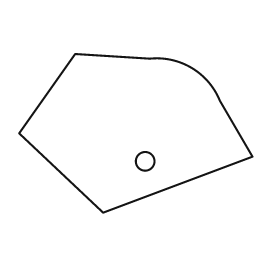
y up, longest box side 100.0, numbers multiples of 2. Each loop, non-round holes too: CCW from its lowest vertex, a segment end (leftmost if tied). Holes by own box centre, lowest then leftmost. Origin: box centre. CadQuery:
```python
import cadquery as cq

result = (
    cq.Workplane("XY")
    .moveTo(-14.0, -34.0)
    .lineTo(50.0, -10.0)
    .lineTo(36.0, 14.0)
    .threePointArc((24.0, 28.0), (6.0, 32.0))
    .lineTo(-26.0, 34.0)
    .lineTo(-50.0, 0.0)
    .close()
    .moveTo(4.0, -12.0)
    .circle(4.0)
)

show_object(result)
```